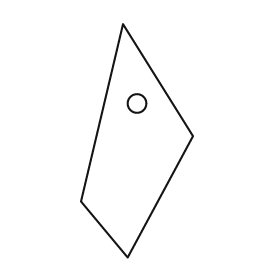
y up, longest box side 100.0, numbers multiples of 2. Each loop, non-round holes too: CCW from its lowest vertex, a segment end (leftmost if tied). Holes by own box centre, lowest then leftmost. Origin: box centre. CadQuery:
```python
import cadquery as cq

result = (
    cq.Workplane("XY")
    .moveTo(-4.0, -50.0)
    .lineTo(24.0, 2.0)
    .lineTo(-6.0, 50.0)
    .lineTo(-24.0, -26.0)
    .close()
    .moveTo(0.0, 16.0)
    .circle(4.0)
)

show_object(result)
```